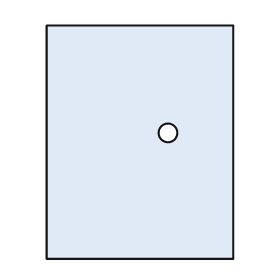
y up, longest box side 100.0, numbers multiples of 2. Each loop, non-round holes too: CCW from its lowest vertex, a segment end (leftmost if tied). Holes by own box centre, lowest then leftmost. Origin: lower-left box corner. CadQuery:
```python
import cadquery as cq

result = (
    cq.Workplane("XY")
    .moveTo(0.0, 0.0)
    .lineTo(80.0, 0.0)
    .lineTo(80.0, 100.0)
    .lineTo(0.0, 100.0)
    .close()
    .moveTo(52.0, 54.0)
    .circle(4.0)
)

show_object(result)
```